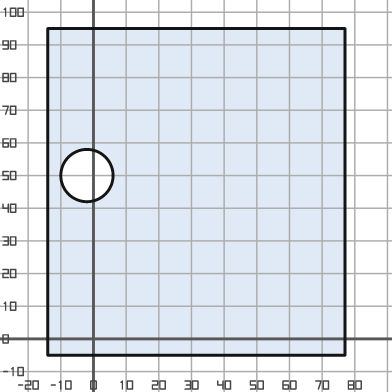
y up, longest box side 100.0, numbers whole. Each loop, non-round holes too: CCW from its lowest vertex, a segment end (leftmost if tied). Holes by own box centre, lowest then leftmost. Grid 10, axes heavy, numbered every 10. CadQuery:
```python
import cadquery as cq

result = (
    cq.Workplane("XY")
    .moveTo(-14.0, -5.0)
    .lineTo(77.0, -5.0)
    .lineTo(77.0, 95.0)
    .lineTo(-14.0, 95.0)
    .close()
    .moveTo(-2.0, 50.0)
    .circle(8.0)
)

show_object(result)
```